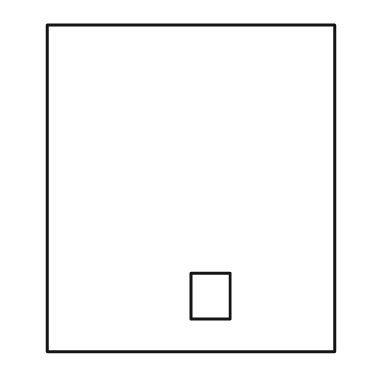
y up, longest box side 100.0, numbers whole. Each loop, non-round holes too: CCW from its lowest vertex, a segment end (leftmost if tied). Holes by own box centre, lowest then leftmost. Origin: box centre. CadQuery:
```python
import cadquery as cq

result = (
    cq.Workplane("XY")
    .moveTo(-44.0, -50.0)
    .lineTo(44.0, -50.0)
    .lineTo(44.0, 50.0)
    .lineTo(-44.0, 50.0)
    .close()
    .moveTo(0.0, -40.0)
    .lineTo(12.0, -40.0)
    .lineTo(12.0, -26.0)
    .lineTo(0.0, -26.0)
    .close()
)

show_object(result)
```